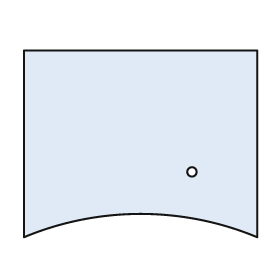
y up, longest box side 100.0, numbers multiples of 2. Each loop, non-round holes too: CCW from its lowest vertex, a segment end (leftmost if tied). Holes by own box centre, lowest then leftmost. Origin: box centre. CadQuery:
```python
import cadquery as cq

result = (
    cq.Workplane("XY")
    .moveTo(-50.0, -40.0)
    .threePointArc((0.0, -30.0), (50.0, -40.0))
    .lineTo(50.0, 40.0)
    .lineTo(-50.0, 40.0)
    .close()
    .moveTo(22.0, -12.0)
    .circle(2.0)
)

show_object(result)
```